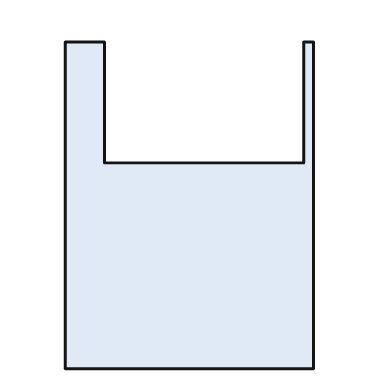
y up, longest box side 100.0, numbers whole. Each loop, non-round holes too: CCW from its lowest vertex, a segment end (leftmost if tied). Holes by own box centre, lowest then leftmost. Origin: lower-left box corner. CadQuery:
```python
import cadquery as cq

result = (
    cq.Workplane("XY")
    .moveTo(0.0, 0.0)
    .lineTo(76.0, 0.0)
    .lineTo(76.0, 100.0)
    .lineTo(73.0, 100.0)
    .lineTo(73.0, 63.0)
    .lineTo(12.0, 63.0)
    .lineTo(12.0, 100.0)
    .lineTo(0.0, 100.0)
    .close()
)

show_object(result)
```